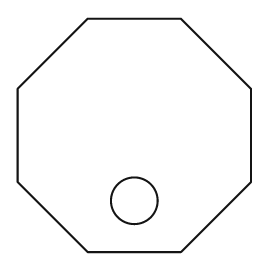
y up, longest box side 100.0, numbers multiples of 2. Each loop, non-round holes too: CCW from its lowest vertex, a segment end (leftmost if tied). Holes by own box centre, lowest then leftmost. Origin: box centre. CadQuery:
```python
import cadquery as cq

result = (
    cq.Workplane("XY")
    .moveTo(-20.0, -50.0)
    .lineTo(20.0, -50.0)
    .lineTo(50.0, -20.0)
    .lineTo(50.0, 20.0)
    .lineTo(20.0, 50.0)
    .lineTo(-20.0, 50.0)
    .lineTo(-50.0, 20.0)
    .lineTo(-50.0, -20.0)
    .close()
    .moveTo(0.0, -28.0)
    .circle(10.0)
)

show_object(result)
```